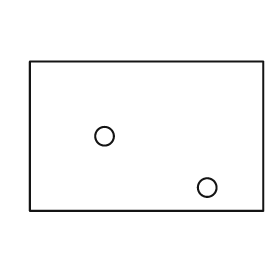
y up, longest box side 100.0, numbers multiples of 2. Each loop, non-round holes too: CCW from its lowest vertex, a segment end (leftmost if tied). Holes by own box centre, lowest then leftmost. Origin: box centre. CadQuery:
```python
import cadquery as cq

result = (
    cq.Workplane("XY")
    .moveTo(-50.0, -32.0)
    .lineTo(50.0, -32.0)
    .lineTo(50.0, 32.0)
    .lineTo(-50.0, 32.0)
    .close()
    .moveTo(26.0, -22.0)
    .circle(4.0)
    .moveTo(-18.0, 0.0)
    .circle(4.0)
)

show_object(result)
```